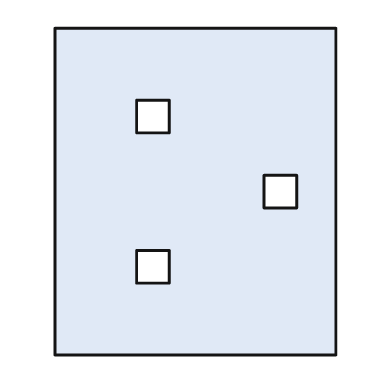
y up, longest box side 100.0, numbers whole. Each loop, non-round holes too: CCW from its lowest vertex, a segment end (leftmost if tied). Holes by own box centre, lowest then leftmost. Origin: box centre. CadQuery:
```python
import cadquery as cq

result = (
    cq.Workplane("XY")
    .moveTo(-43.0, -50.0)
    .lineTo(43.0, -50.0)
    .lineTo(43.0, 50.0)
    .lineTo(-43.0, 50.0)
    .close()
    .moveTo(-18.0, -28.0)
    .lineTo(-8.0, -28.0)
    .lineTo(-8.0, -18.0)
    .lineTo(-18.0, -18.0)
    .close()
    .moveTo(21.0, -5.0)
    .lineTo(31.0, -5.0)
    .lineTo(31.0, 5.0)
    .lineTo(21.0, 5.0)
    .close()
    .moveTo(-18.0, 18.0)
    .lineTo(-8.0, 18.0)
    .lineTo(-8.0, 28.0)
    .lineTo(-18.0, 28.0)
    .close()
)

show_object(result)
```